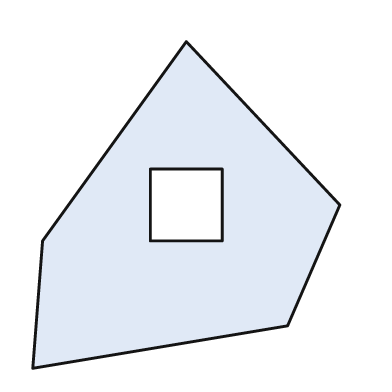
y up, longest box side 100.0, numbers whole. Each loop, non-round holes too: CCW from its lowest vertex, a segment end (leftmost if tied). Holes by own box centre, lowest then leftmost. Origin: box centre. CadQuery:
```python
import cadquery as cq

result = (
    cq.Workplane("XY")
    .moveTo(-47.0, -50.0)
    .lineTo(31.0, -37.0)
    .lineTo(47.0, 0.0)
    .lineTo(0.0, 50.0)
    .lineTo(-44.0, -11.0)
    .close()
    .moveTo(-11.0, -11.0)
    .lineTo(11.0, -11.0)
    .lineTo(11.0, 11.0)
    .lineTo(-11.0, 11.0)
    .close()
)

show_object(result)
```